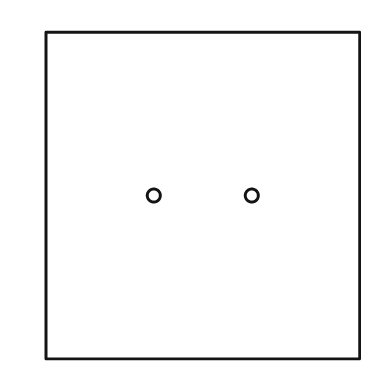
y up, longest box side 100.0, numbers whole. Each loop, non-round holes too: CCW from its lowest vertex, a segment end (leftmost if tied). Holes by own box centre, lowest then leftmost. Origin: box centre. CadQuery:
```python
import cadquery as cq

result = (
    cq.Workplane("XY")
    .moveTo(-48.0, -50.0)
    .lineTo(48.0, -50.0)
    .lineTo(48.0, 50.0)
    .lineTo(-48.0, 50.0)
    .close()
    .moveTo(-15.0, 0.0)
    .circle(2.0)
    .moveTo(15.0, 0.0)
    .circle(2.0)
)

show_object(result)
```